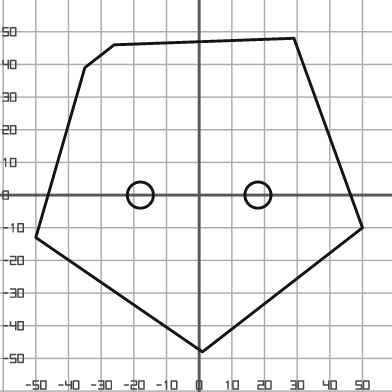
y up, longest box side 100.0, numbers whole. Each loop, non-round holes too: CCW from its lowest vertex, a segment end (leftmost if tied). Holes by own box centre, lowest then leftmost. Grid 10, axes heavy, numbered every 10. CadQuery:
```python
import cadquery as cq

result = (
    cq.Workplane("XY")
    .moveTo(1.0, -48.0)
    .lineTo(50.0, -10.0)
    .lineTo(29.0, 48.0)
    .lineTo(-26.0, 46.0)
    .lineTo(-35.0, 39.0)
    .lineTo(-50.0, -13.0)
    .close()
    .moveTo(-18.0, 0.0)
    .circle(4.0)
    .moveTo(18.0, 0.0)
    .circle(4.0)
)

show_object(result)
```